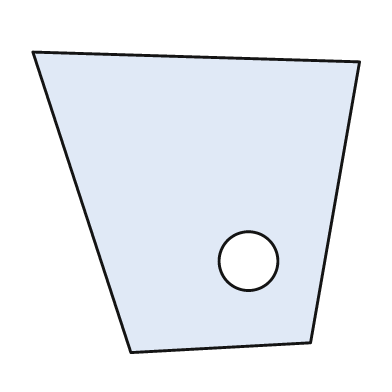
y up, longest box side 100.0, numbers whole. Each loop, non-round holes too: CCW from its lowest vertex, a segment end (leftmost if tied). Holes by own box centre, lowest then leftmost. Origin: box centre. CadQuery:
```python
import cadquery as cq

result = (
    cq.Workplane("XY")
    .moveTo(-20.0, -46.0)
    .lineTo(35.0, -43.0)
    .lineTo(50.0, 43.0)
    .lineTo(-50.0, 46.0)
    .close()
    .moveTo(16.0, -18.0)
    .circle(9.0)
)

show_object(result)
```